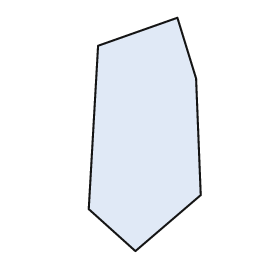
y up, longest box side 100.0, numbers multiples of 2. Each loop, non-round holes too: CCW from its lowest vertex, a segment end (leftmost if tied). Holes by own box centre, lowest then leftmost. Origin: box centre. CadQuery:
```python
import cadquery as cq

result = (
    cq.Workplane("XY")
    .moveTo(-4.0, -50.0)
    .lineTo(24.0, -26.0)
    .lineTo(22.0, 24.0)
    .lineTo(14.0, 50.0)
    .lineTo(-20.0, 38.0)
    .lineTo(-24.0, -32.0)
    .close()
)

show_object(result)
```